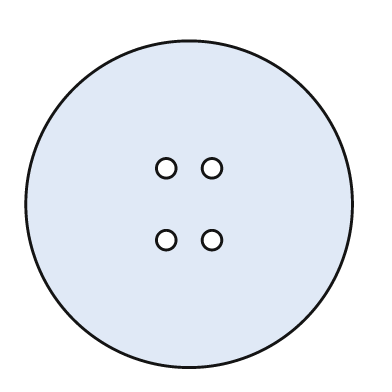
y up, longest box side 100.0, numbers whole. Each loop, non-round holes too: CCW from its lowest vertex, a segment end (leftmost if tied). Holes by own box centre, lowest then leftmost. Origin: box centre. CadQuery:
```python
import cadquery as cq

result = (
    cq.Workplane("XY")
    .moveTo(0.0, 0.0)
    .circle(50.0)
    .moveTo(-7.0, -11.0)
    .circle(3.0)
    .moveTo(7.0, -11.0)
    .circle(3.0)
    .moveTo(-7.0, 11.0)
    .circle(3.0)
    .moveTo(7.0, 11.0)
    .circle(3.0)
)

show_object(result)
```